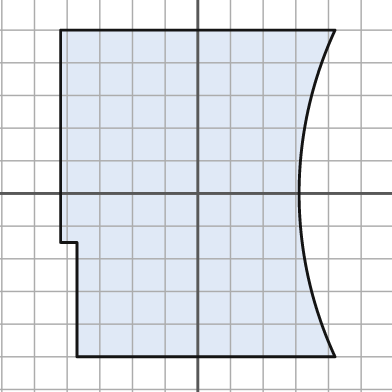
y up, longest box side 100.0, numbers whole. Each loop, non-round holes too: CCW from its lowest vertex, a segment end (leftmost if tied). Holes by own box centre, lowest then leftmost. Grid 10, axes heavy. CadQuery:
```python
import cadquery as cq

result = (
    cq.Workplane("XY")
    .moveTo(-37.0, -50.0)
    .lineTo(42.0, -50.0)
    .threePointArc((31.0, 0.0), (42.0, 50.0))
    .lineTo(-42.0, 50.0)
    .lineTo(-42.0, -15.0)
    .lineTo(-37.0, -15.0)
    .close()
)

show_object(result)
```